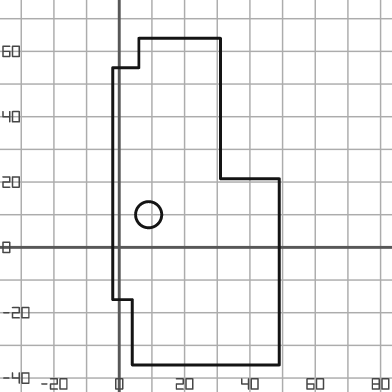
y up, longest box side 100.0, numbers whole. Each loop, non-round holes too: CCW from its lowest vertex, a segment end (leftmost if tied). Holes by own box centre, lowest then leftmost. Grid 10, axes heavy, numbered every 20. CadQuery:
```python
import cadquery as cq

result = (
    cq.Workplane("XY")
    .moveTo(4.0, -36.0)
    .lineTo(49.0, -36.0)
    .lineTo(49.0, 21.0)
    .lineTo(31.0, 21.0)
    .lineTo(31.0, 64.0)
    .lineTo(6.0, 64.0)
    .lineTo(6.0, 55.0)
    .lineTo(-2.0, 55.0)
    .lineTo(-2.0, -16.0)
    .lineTo(4.0, -16.0)
    .close()
    .moveTo(9.0, 10.0)
    .circle(4.0)
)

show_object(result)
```